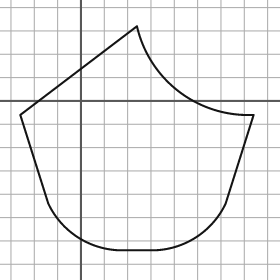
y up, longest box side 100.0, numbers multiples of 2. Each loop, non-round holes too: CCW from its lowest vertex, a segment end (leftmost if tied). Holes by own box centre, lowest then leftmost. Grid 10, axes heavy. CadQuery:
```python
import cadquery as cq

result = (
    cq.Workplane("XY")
    .moveTo(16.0, -64.0)
    .lineTo(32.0, -64.0)
    .threePointArc((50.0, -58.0), (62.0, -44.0))
    .lineTo(74.0, -6.0)
    .threePointArc((42.0, 4.0), (24.0, 32.0))
    .lineTo(-26.0, -6.0)
    .lineTo(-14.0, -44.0)
    .threePointArc((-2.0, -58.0), (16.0, -64.0))
    .close()
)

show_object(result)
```